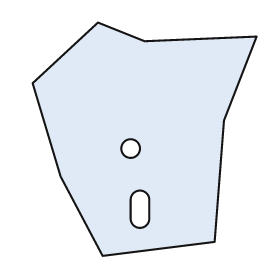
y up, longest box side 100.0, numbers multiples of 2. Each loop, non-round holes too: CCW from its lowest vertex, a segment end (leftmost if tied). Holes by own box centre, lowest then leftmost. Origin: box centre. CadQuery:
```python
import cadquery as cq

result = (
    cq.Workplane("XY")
    .moveTo(-18.0, -50.0)
    .lineTo(30.0, -44.0)
    .lineTo(34.0, 8.0)
    .lineTo(48.0, 44.0)
    .lineTo(0.0, 42.0)
    .lineTo(-20.0, 50.0)
    .lineTo(-48.0, 24.0)
    .lineTo(-36.0, -16.0)
    .close()
    .moveTo(-6.0, -34.0)
    .threePointArc((-2.0, -38.0), (2.0, -34.0))
    .lineTo(2.0, -26.0)
    .threePointArc((-2.0, -22.0), (-6.0, -26.0))
    .close()
    .moveTo(-6.0, -4.0)
    .circle(4.0)
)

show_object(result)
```